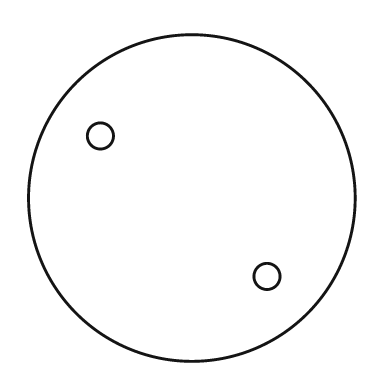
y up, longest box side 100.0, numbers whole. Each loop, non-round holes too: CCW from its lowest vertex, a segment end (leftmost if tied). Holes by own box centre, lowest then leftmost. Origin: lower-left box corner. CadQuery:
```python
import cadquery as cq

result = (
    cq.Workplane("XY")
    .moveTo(50.0, 50.0)
    .circle(50.0)
    .moveTo(73.0, 26.0)
    .circle(4.0)
    .moveTo(22.0, 69.0)
    .circle(4.0)
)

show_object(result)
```